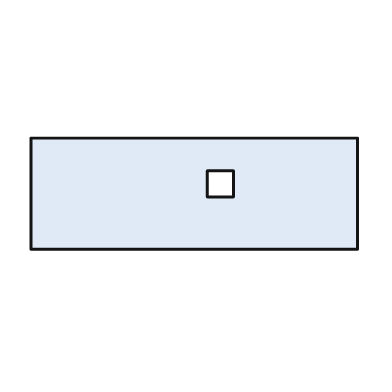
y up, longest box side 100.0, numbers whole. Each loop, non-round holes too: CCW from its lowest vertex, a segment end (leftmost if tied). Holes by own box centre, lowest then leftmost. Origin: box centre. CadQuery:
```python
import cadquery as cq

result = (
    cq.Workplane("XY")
    .moveTo(-50.0, -17.0)
    .lineTo(50.0, -17.0)
    .lineTo(50.0, 17.0)
    .lineTo(-50.0, 17.0)
    .close()
    .moveTo(4.0, -1.0)
    .lineTo(12.0, -1.0)
    .lineTo(12.0, 7.0)
    .lineTo(4.0, 7.0)
    .close()
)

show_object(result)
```